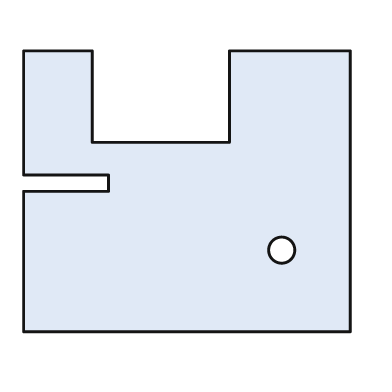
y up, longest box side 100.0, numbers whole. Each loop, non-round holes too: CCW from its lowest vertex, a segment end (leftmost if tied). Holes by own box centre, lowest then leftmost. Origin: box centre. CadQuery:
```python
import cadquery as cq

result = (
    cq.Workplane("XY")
    .moveTo(-50.0, -43.0)
    .lineTo(50.0, -43.0)
    .lineTo(50.0, 43.0)
    .lineTo(13.0, 43.0)
    .lineTo(13.0, 15.0)
    .lineTo(-29.0, 15.0)
    .lineTo(-29.0, 43.0)
    .lineTo(-50.0, 43.0)
    .lineTo(-50.0, 5.0)
    .lineTo(-24.0, 5.0)
    .lineTo(-24.0, 0.0)
    .lineTo(-50.0, 0.0)
    .close()
    .moveTo(29.0, -18.0)
    .circle(4.0)
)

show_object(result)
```